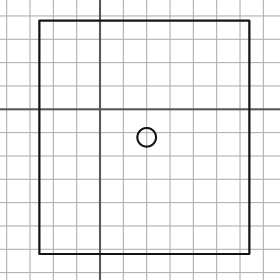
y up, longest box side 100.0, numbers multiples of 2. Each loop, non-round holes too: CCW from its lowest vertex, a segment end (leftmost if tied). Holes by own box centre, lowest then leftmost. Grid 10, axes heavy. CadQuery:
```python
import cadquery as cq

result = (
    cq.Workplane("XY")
    .moveTo(-26.0, -62.0)
    .lineTo(64.0, -62.0)
    .lineTo(64.0, 38.0)
    .lineTo(-26.0, 38.0)
    .close()
    .moveTo(20.0, -12.0)
    .circle(4.0)
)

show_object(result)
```